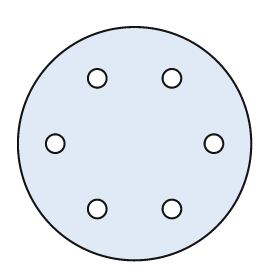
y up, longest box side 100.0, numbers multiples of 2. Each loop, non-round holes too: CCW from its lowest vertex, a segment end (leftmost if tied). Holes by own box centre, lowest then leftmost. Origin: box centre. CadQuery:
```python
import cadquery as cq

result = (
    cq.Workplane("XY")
    .moveTo(0.0, 0.0)
    .circle(50.0)
    .moveTo(-16.0, -28.0)
    .circle(4.0)
    .moveTo(16.0, -28.0)
    .circle(4.0)
    .moveTo(-34.0, 0.0)
    .circle(4.0)
    .moveTo(34.0, 0.0)
    .circle(4.0)
    .moveTo(-16.0, 28.0)
    .circle(4.0)
    .moveTo(16.0, 28.0)
    .circle(4.0)
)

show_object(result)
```